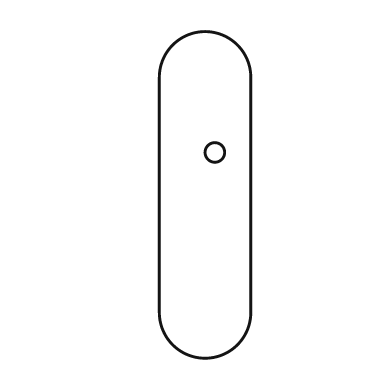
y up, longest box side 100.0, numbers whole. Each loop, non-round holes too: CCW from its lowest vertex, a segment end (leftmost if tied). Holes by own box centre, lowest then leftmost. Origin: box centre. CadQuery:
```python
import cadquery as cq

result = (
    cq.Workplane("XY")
    .moveTo(-14.0, -36.0)
    .threePointArc((0.0, -50.0), (14.0, -36.0))
    .lineTo(14.0, 36.0)
    .threePointArc((0.0, 50.0), (-14.0, 36.0))
    .close()
    .moveTo(3.0, 13.0)
    .circle(3.0)
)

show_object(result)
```